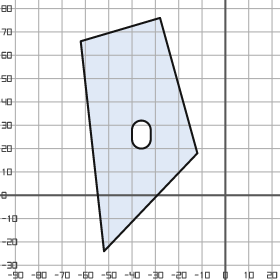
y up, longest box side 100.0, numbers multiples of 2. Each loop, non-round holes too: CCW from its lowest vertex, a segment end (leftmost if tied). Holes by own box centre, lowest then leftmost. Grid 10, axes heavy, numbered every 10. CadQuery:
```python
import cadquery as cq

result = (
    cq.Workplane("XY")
    .moveTo(-52.0, -24.0)
    .lineTo(-12.0, 18.0)
    .lineTo(-28.0, 76.0)
    .lineTo(-62.0, 66.0)
    .close()
    .moveTo(-40.0, 24.0)
    .threePointArc((-36.0, 20.0), (-32.0, 24.0))
    .lineTo(-32.0, 28.0)
    .threePointArc((-36.0, 32.0), (-40.0, 28.0))
    .close()
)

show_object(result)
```